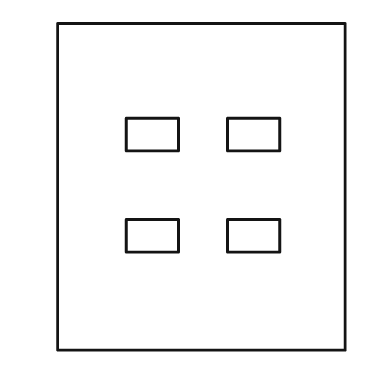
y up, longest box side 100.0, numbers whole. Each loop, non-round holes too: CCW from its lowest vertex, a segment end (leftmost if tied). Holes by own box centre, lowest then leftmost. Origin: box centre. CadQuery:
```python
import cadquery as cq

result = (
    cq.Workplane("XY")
    .moveTo(-44.0, -50.0)
    .lineTo(44.0, -50.0)
    .lineTo(44.0, 50.0)
    .lineTo(-44.0, 50.0)
    .close()
    .moveTo(-23.0, -20.0)
    .lineTo(-7.0, -20.0)
    .lineTo(-7.0, -10.0)
    .lineTo(-23.0, -10.0)
    .close()
    .moveTo(8.0, -20.0)
    .lineTo(24.0, -20.0)
    .lineTo(24.0, -10.0)
    .lineTo(8.0, -10.0)
    .close()
    .moveTo(-23.0, 11.0)
    .lineTo(-7.0, 11.0)
    .lineTo(-7.0, 21.0)
    .lineTo(-23.0, 21.0)
    .close()
    .moveTo(8.0, 11.0)
    .lineTo(24.0, 11.0)
    .lineTo(24.0, 21.0)
    .lineTo(8.0, 21.0)
    .close()
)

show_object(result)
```